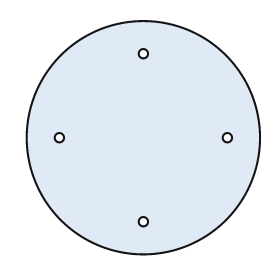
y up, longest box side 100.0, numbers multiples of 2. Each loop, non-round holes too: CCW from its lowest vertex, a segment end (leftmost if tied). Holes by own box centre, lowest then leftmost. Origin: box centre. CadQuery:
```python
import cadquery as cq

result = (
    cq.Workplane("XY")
    .moveTo(0.0, 0.0)
    .circle(50.0)
    .moveTo(0.0, -36.0)
    .circle(2.0)
    .moveTo(-36.0, 0.0)
    .circle(2.0)
    .moveTo(36.0, 0.0)
    .circle(2.0)
    .moveTo(0.0, 36.0)
    .circle(2.0)
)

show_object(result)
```